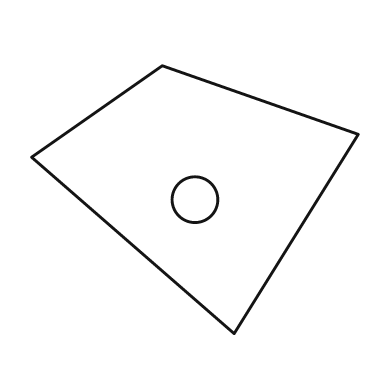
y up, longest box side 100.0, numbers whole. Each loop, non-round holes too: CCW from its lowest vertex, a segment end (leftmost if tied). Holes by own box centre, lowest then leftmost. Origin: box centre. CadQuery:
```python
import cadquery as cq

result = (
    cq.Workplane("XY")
    .moveTo(12.0, -41.0)
    .lineTo(50.0, 20.0)
    .lineTo(-10.0, 41.0)
    .lineTo(-50.0, 13.0)
    .close()
    .moveTo(0.0, 0.0)
    .circle(7.0)
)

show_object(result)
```